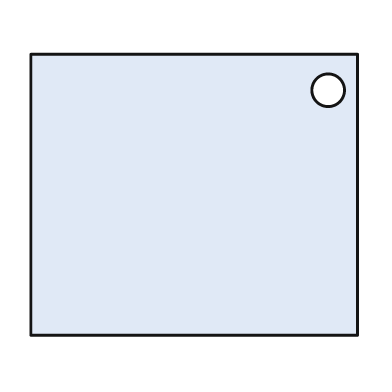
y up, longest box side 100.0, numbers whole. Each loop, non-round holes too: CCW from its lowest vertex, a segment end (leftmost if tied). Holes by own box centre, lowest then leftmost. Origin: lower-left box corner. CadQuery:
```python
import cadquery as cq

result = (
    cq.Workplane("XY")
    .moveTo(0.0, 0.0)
    .lineTo(100.0, 0.0)
    .lineTo(100.0, 86.0)
    .lineTo(0.0, 86.0)
    .close()
    .moveTo(91.0, 75.0)
    .circle(5.0)
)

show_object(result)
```